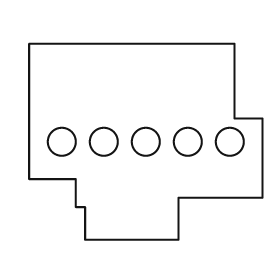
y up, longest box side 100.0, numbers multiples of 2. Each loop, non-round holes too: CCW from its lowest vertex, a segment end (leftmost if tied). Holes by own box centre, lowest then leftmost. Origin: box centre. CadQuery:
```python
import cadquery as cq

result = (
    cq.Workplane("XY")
    .moveTo(-26.0, -42.0)
    .lineTo(14.0, -42.0)
    .lineTo(14.0, -24.0)
    .lineTo(50.0, -24.0)
    .lineTo(50.0, 10.0)
    .lineTo(38.0, 10.0)
    .lineTo(38.0, 42.0)
    .lineTo(-50.0, 42.0)
    .lineTo(-50.0, -16.0)
    .lineTo(-30.0, -16.0)
    .lineTo(-30.0, -28.0)
    .lineTo(-26.0, -28.0)
    .close()
    .moveTo(-36.0, 0.0)
    .circle(6.0)
    .moveTo(-18.0, 0.0)
    .circle(6.0)
    .moveTo(0.0, 0.0)
    .circle(6.0)
    .moveTo(18.0, 0.0)
    .circle(6.0)
    .moveTo(36.0, 0.0)
    .circle(6.0)
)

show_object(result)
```